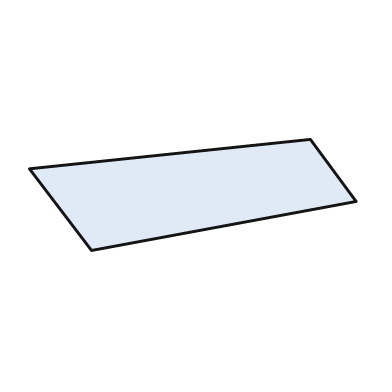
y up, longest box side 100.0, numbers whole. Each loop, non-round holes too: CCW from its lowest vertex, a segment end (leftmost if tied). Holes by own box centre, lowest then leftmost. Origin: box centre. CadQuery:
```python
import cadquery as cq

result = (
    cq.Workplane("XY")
    .moveTo(-31.0, -17.0)
    .lineTo(50.0, -2.0)
    .lineTo(36.0, 17.0)
    .lineTo(-50.0, 8.0)
    .close()
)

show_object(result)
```